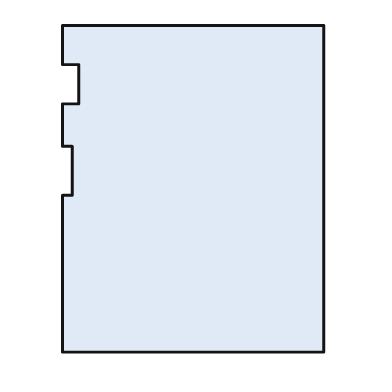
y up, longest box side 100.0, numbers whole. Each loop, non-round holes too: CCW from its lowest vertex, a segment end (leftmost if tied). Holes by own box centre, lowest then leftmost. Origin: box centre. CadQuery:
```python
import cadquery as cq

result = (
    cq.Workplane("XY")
    .moveTo(-40.0, -50.0)
    .lineTo(40.0, -50.0)
    .lineTo(40.0, 50.0)
    .lineTo(-40.0, 50.0)
    .lineTo(-40.0, 38.0)
    .lineTo(-35.0, 38.0)
    .lineTo(-35.0, 26.0)
    .lineTo(-40.0, 26.0)
    .lineTo(-40.0, 13.0)
    .lineTo(-37.0, 13.0)
    .lineTo(-37.0, -2.0)
    .lineTo(-40.0, -2.0)
    .close()
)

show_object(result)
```